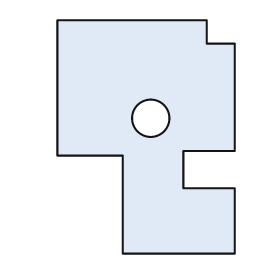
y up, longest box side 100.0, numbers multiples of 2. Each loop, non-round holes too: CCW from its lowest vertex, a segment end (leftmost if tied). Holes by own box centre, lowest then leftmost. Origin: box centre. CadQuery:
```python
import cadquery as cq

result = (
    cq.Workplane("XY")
    .moveTo(-10.0, -50.0)
    .lineTo(38.0, -50.0)
    .lineTo(38.0, -22.0)
    .lineTo(16.0, -22.0)
    .lineTo(16.0, -6.0)
    .lineTo(38.0, -6.0)
    .lineTo(38.0, 40.0)
    .lineTo(26.0, 40.0)
    .lineTo(26.0, 50.0)
    .lineTo(-38.0, 50.0)
    .lineTo(-38.0, -8.0)
    .lineTo(-10.0, -8.0)
    .close()
    .moveTo(2.0, 8.0)
    .circle(8.0)
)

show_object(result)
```